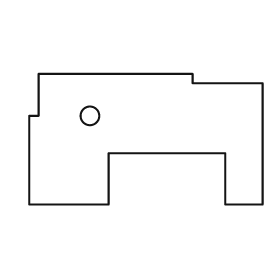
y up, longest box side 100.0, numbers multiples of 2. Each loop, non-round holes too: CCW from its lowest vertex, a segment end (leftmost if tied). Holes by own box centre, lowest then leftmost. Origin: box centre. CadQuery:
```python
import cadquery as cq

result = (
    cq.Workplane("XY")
    .moveTo(-50.0, -28.0)
    .lineTo(-16.0, -28.0)
    .lineTo(-16.0, -6.0)
    .lineTo(34.0, -6.0)
    .lineTo(34.0, -28.0)
    .lineTo(50.0, -28.0)
    .lineTo(50.0, 24.0)
    .lineTo(20.0, 24.0)
    .lineTo(20.0, 28.0)
    .lineTo(-46.0, 28.0)
    .lineTo(-46.0, 10.0)
    .lineTo(-50.0, 10.0)
    .close()
    .moveTo(-24.0, 10.0)
    .circle(4.0)
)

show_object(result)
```